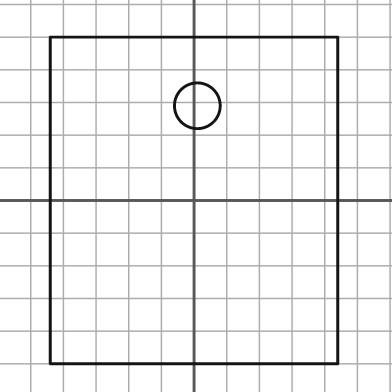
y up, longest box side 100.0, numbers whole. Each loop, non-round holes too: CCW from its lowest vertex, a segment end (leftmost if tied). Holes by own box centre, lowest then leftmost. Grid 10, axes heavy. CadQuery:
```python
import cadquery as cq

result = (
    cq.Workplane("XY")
    .moveTo(-44.0, -50.0)
    .lineTo(44.0, -50.0)
    .lineTo(44.0, 50.0)
    .lineTo(-44.0, 50.0)
    .close()
    .moveTo(1.0, 29.0)
    .circle(7.0)
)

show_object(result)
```